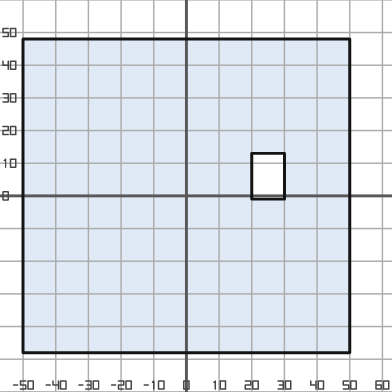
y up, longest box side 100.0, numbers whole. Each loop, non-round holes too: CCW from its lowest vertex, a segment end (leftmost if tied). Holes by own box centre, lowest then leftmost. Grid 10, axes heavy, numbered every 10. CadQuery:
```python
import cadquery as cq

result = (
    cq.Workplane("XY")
    .moveTo(-50.0, -48.0)
    .lineTo(50.0, -48.0)
    .lineTo(50.0, 48.0)
    .lineTo(-50.0, 48.0)
    .close()
    .moveTo(20.0, -1.0)
    .lineTo(30.0, -1.0)
    .lineTo(30.0, 13.0)
    .lineTo(20.0, 13.0)
    .close()
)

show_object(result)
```